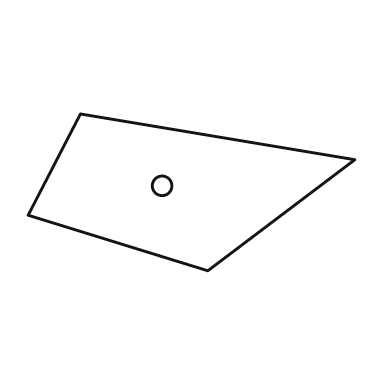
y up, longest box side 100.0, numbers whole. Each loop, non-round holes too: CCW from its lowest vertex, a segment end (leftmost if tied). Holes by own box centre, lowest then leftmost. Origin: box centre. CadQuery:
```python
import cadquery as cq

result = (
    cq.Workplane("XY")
    .moveTo(5.0, -24.0)
    .lineTo(50.0, 10.0)
    .lineTo(-34.0, 24.0)
    .lineTo(-50.0, -7.0)
    .close()
    .moveTo(-9.0, 2.0)
    .circle(3.0)
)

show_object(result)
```